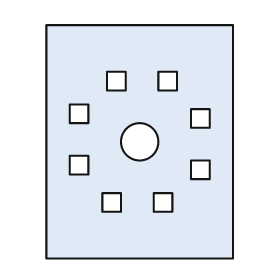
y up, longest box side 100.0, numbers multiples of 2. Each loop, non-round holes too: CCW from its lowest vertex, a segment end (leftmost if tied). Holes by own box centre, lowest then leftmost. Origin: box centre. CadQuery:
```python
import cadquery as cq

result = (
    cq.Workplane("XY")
    .moveTo(-40.0, -50.0)
    .lineTo(40.0, -50.0)
    .lineTo(40.0, 50.0)
    .lineTo(-40.0, 50.0)
    .close()
    .moveTo(-16.0, -30.0)
    .lineTo(-8.0, -30.0)
    .lineTo(-8.0, -22.0)
    .lineTo(-16.0, -22.0)
    .close()
    .moveTo(6.0, -30.0)
    .lineTo(14.0, -30.0)
    .lineTo(14.0, -22.0)
    .lineTo(6.0, -22.0)
    .close()
    .moveTo(22.0, -16.0)
    .lineTo(30.0, -16.0)
    .lineTo(30.0, -8.0)
    .lineTo(22.0, -8.0)
    .close()
    .moveTo(-30.0, -14.0)
    .lineTo(-22.0, -14.0)
    .lineTo(-22.0, -6.0)
    .lineTo(-30.0, -6.0)
    .close()
    .moveTo(0.0, 0.0)
    .circle(8.0)
    .moveTo(22.0, 6.0)
    .lineTo(30.0, 6.0)
    .lineTo(30.0, 14.0)
    .lineTo(22.0, 14.0)
    .close()
    .moveTo(-30.0, 8.0)
    .lineTo(-22.0, 8.0)
    .lineTo(-22.0, 16.0)
    .lineTo(-30.0, 16.0)
    .close()
    .moveTo(-14.0, 22.0)
    .lineTo(-6.0, 22.0)
    .lineTo(-6.0, 30.0)
    .lineTo(-14.0, 30.0)
    .close()
    .moveTo(8.0, 22.0)
    .lineTo(16.0, 22.0)
    .lineTo(16.0, 30.0)
    .lineTo(8.0, 30.0)
    .close()
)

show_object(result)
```